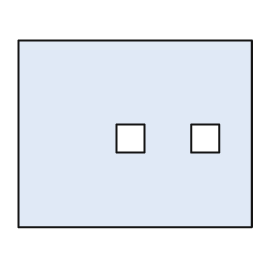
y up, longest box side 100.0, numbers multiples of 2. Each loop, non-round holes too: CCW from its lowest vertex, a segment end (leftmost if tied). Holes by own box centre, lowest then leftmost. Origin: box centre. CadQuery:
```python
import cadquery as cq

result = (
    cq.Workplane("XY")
    .moveTo(-50.0, -40.0)
    .lineTo(50.0, -40.0)
    .lineTo(50.0, 40.0)
    .lineTo(-50.0, 40.0)
    .close()
    .moveTo(-8.0, -8.0)
    .lineTo(4.0, -8.0)
    .lineTo(4.0, 4.0)
    .lineTo(-8.0, 4.0)
    .close()
    .moveTo(24.0, -8.0)
    .lineTo(36.0, -8.0)
    .lineTo(36.0, 4.0)
    .lineTo(24.0, 4.0)
    .close()
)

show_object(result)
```